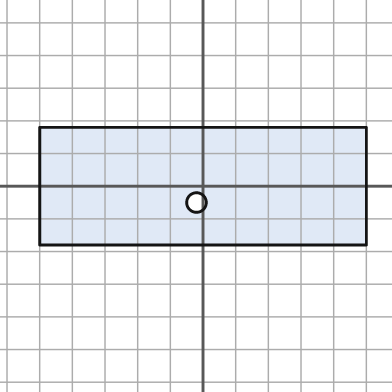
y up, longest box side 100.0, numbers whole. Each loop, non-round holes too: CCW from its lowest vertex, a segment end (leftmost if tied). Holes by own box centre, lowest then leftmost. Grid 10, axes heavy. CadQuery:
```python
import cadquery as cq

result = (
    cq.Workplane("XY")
    .moveTo(-50.0, -18.0)
    .lineTo(50.0, -18.0)
    .lineTo(50.0, 18.0)
    .lineTo(-50.0, 18.0)
    .close()
    .moveTo(-2.0, -5.0)
    .circle(3.0)
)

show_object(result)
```